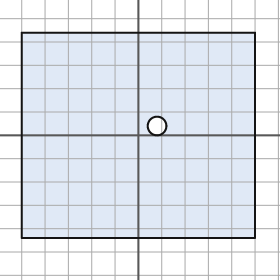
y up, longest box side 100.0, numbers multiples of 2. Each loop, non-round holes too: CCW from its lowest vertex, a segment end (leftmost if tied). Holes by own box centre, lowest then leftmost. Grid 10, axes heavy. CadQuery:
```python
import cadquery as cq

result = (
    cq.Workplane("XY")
    .moveTo(-50.0, -44.0)
    .lineTo(50.0, -44.0)
    .lineTo(50.0, 44.0)
    .lineTo(-50.0, 44.0)
    .close()
    .moveTo(8.0, 4.0)
    .circle(4.0)
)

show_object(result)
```